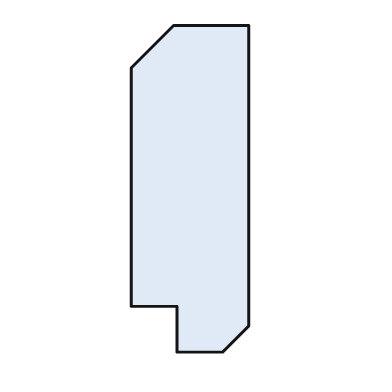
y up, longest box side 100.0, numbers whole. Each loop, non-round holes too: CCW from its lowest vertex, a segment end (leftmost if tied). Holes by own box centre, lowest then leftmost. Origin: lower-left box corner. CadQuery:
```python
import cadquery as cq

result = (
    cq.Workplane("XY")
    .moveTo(14.0, 0.0)
    .lineTo(28.0, 0.0)
    .lineTo(36.0, 8.0)
    .lineTo(36.0, 100.0)
    .lineTo(13.0, 100.0)
    .lineTo(0.0, 87.0)
    .lineTo(0.0, 14.0)
    .lineTo(14.0, 14.0)
    .close()
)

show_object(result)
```